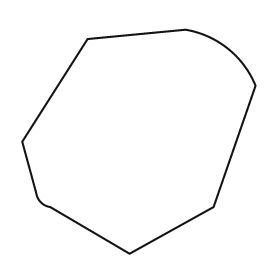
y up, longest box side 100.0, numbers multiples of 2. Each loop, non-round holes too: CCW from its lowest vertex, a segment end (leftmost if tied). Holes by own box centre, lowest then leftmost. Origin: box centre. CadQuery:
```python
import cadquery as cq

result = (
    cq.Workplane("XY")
    .moveTo(-4.0, -48.0)
    .lineTo(32.0, -28.0)
    .lineTo(50.0, 24.0)
    .threePointArc((38.0, 40.0), (20.0, 48.0))
    .lineTo(-22.0, 44.0)
    .lineTo(-50.0, 0.0)
    .lineTo(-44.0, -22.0)
    .threePointArc((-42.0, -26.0), (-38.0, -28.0))
    .close()
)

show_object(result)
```